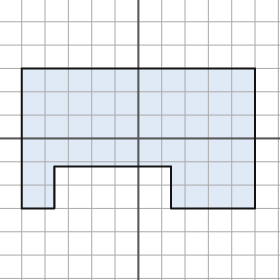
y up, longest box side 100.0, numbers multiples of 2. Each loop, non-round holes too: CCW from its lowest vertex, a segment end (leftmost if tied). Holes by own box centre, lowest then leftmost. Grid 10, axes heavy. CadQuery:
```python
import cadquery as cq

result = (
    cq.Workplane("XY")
    .moveTo(-50.0, -30.0)
    .lineTo(-36.0, -30.0)
    .lineTo(-36.0, -12.0)
    .lineTo(14.0, -12.0)
    .lineTo(14.0, -30.0)
    .lineTo(50.0, -30.0)
    .lineTo(50.0, 30.0)
    .lineTo(-50.0, 30.0)
    .close()
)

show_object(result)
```